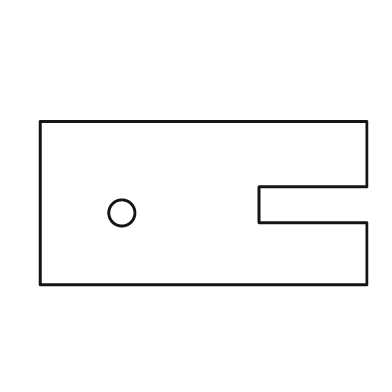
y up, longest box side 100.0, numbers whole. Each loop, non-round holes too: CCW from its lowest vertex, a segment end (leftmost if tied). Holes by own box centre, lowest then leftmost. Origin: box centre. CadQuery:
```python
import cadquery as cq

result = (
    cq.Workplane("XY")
    .moveTo(-50.0, -25.0)
    .lineTo(50.0, -25.0)
    .lineTo(50.0, -6.0)
    .lineTo(17.0, -6.0)
    .lineTo(17.0, 5.0)
    .lineTo(50.0, 5.0)
    .lineTo(50.0, 25.0)
    .lineTo(-50.0, 25.0)
    .close()
    .moveTo(-25.0, -3.0)
    .circle(4.0)
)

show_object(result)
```